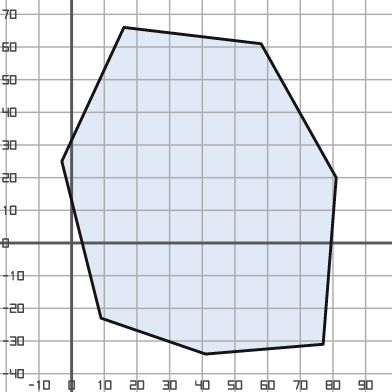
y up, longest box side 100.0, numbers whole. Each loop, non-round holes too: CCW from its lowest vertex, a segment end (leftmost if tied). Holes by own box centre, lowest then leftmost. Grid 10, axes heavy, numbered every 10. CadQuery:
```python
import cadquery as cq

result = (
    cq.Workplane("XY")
    .moveTo(41.0, -34.0)
    .lineTo(77.0, -31.0)
    .lineTo(81.0, 20.0)
    .lineTo(58.0, 61.0)
    .lineTo(16.0, 66.0)
    .lineTo(-3.0, 25.0)
    .lineTo(9.0, -23.0)
    .close()
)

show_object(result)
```